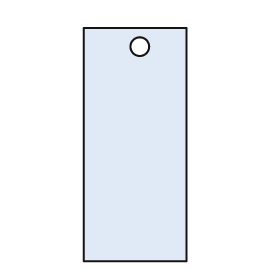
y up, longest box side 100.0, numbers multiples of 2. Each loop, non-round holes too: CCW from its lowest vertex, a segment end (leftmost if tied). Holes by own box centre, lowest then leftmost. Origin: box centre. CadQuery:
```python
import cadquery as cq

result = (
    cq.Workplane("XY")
    .moveTo(-22.0, -50.0)
    .lineTo(22.0, -50.0)
    .lineTo(22.0, 50.0)
    .lineTo(-22.0, 50.0)
    .close()
    .moveTo(2.0, 42.0)
    .circle(4.0)
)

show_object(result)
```